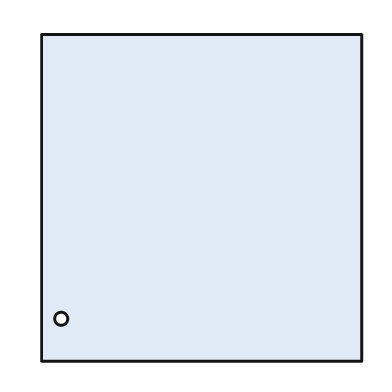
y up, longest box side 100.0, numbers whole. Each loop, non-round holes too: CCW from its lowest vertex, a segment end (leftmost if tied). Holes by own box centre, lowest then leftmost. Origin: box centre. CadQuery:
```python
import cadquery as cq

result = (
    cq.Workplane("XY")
    .moveTo(-49.0, -50.0)
    .lineTo(49.0, -50.0)
    .lineTo(49.0, 50.0)
    .lineTo(-49.0, 50.0)
    .close()
    .moveTo(-43.0, -37.0)
    .circle(2.0)
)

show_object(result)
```